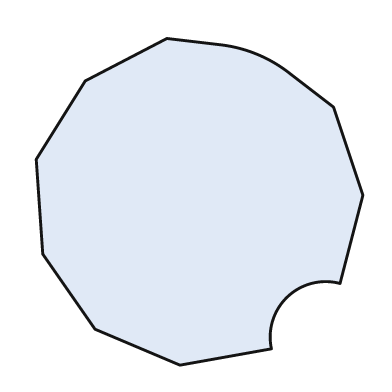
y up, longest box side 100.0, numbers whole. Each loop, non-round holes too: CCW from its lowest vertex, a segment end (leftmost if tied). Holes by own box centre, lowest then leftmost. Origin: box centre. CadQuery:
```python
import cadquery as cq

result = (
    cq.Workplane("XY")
    .moveTo(-6.0, -50.0)
    .lineTo(22.0, -45.0)
    .threePointArc((27.0, -29.0), (43.0, -25.0))
    .lineTo(50.0, 2.0)
    .lineTo(41.0, 29.0)
    .lineTo(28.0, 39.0)
    .threePointArc((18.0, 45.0), (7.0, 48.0))
    .lineTo(-10.0, 50.0)
    .lineTo(-35.0, 37.0)
    .lineTo(-50.0, 13.0)
    .lineTo(-48.0, -16.0)
    .lineTo(-32.0, -39.0)
    .close()
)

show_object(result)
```